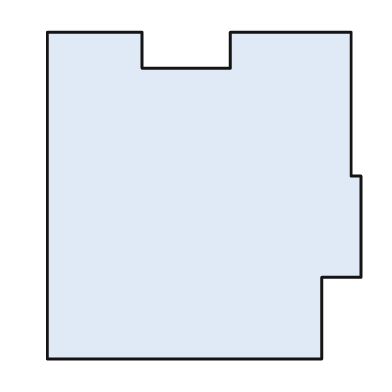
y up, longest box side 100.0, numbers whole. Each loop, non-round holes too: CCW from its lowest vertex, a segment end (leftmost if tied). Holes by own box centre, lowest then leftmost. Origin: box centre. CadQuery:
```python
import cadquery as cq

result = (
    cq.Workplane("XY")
    .moveTo(-48.0, -50.0)
    .lineTo(36.0, -50.0)
    .lineTo(36.0, -25.0)
    .lineTo(48.0, -25.0)
    .lineTo(48.0, 6.0)
    .lineTo(45.0, 6.0)
    .lineTo(45.0, 50.0)
    .lineTo(8.0, 50.0)
    .lineTo(8.0, 39.0)
    .lineTo(-19.0, 39.0)
    .lineTo(-19.0, 50.0)
    .lineTo(-48.0, 50.0)
    .close()
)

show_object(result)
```